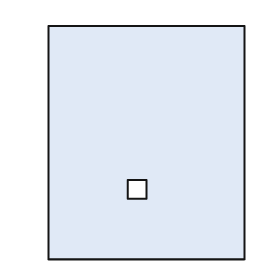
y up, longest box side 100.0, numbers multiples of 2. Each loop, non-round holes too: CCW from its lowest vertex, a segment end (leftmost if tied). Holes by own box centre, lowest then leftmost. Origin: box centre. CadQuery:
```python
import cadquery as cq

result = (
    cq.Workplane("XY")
    .moveTo(-42.0, -50.0)
    .lineTo(42.0, -50.0)
    .lineTo(42.0, 50.0)
    .lineTo(-42.0, 50.0)
    .close()
    .moveTo(-8.0, -24.0)
    .lineTo(0.0, -24.0)
    .lineTo(0.0, -16.0)
    .lineTo(-8.0, -16.0)
    .close()
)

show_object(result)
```